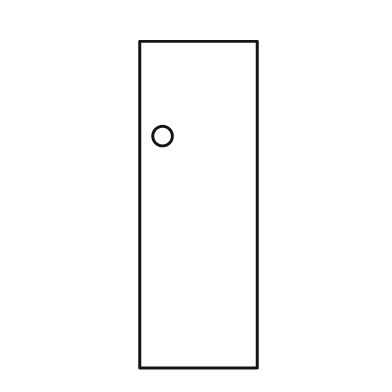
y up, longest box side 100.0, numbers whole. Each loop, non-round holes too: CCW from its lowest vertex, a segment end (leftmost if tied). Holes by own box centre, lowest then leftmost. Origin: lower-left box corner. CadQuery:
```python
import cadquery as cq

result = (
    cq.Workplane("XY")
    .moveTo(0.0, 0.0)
    .lineTo(36.0, 0.0)
    .lineTo(36.0, 100.0)
    .lineTo(0.0, 100.0)
    .close()
    .moveTo(7.0, 71.0)
    .circle(3.0)
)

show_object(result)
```